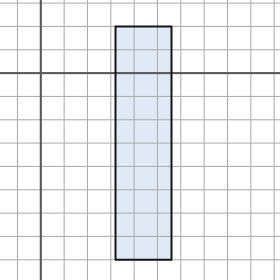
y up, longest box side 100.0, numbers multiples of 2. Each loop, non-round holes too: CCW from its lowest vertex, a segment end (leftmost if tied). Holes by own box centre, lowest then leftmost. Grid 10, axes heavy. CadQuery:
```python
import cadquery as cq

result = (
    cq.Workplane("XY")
    .moveTo(32.0, -80.0)
    .lineTo(56.0, -80.0)
    .lineTo(56.0, 20.0)
    .lineTo(32.0, 20.0)
    .close()
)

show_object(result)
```